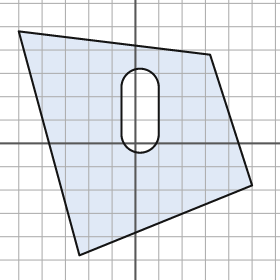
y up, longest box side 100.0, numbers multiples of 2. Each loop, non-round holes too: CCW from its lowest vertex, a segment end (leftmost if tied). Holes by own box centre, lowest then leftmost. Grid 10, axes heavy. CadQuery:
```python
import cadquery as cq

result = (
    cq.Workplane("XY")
    .moveTo(-24.0, -48.0)
    .lineTo(50.0, -18.0)
    .lineTo(32.0, 38.0)
    .lineTo(-50.0, 48.0)
    .close()
    .moveTo(-6.0, 4.0)
    .threePointArc((2.0, -4.0), (10.0, 4.0))
    .lineTo(10.0, 24.0)
    .threePointArc((2.0, 32.0), (-6.0, 24.0))
    .close()
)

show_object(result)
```